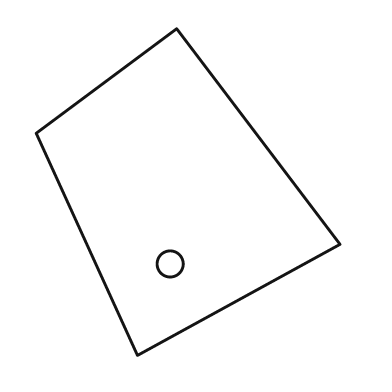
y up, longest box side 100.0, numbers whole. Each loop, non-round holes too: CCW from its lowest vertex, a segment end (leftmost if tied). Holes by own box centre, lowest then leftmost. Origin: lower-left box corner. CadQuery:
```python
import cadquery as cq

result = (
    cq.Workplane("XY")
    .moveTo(31.0, 0.0)
    .lineTo(93.0, 34.0)
    .lineTo(43.0, 100.0)
    .lineTo(0.0, 68.0)
    .close()
    .moveTo(41.0, 28.0)
    .circle(4.0)
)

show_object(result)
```